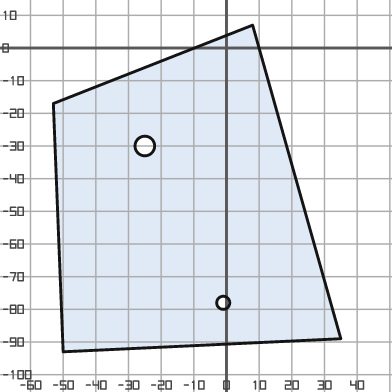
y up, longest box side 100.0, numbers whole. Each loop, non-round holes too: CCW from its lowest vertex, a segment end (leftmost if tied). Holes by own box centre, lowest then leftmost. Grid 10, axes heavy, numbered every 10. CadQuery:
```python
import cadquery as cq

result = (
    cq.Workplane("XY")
    .moveTo(-50.0, -93.0)
    .lineTo(35.0, -89.0)
    .lineTo(8.0, 7.0)
    .lineTo(-53.0, -17.0)
    .close()
    .moveTo(-1.0, -78.0)
    .circle(2.0)
    .moveTo(-25.0, -30.0)
    .circle(3.0)
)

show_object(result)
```